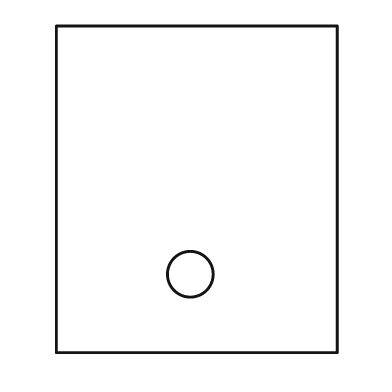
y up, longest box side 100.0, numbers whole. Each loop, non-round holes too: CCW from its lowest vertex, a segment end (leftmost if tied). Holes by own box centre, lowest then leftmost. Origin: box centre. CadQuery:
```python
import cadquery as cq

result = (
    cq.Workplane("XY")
    .moveTo(-43.0, -50.0)
    .lineTo(43.0, -50.0)
    .lineTo(43.0, 50.0)
    .lineTo(-43.0, 50.0)
    .close()
    .moveTo(-2.0, -26.0)
    .circle(7.0)
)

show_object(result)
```